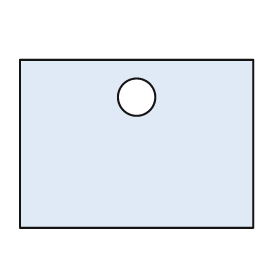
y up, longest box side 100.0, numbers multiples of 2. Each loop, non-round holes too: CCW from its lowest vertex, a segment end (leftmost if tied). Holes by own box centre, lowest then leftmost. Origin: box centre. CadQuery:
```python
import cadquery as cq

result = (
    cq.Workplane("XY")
    .moveTo(-50.0, -36.0)
    .lineTo(50.0, -36.0)
    .lineTo(50.0, 36.0)
    .lineTo(-50.0, 36.0)
    .close()
    .moveTo(0.0, 20.0)
    .circle(8.0)
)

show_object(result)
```